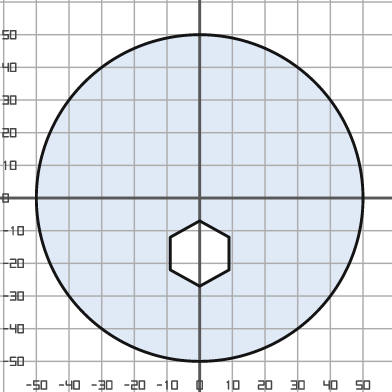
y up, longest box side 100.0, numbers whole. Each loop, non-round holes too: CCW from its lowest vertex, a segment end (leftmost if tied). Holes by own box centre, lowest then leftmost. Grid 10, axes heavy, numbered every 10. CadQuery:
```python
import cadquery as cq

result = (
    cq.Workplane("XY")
    .moveTo(0.0, 0.0)
    .circle(50.0)
    .moveTo(0.0, -27.0)
    .lineTo(9.0, -22.0)
    .lineTo(9.0, -12.0)
    .lineTo(0.0, -7.0)
    .lineTo(-9.0, -12.0)
    .lineTo(-9.0, -22.0)
    .close()
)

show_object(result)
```